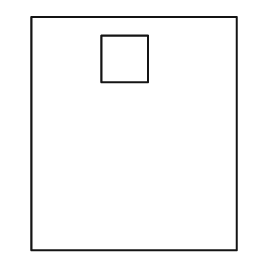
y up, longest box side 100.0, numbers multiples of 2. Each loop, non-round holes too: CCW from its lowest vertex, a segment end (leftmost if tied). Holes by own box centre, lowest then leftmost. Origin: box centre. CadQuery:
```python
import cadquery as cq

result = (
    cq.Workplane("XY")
    .moveTo(-44.0, -50.0)
    .lineTo(44.0, -50.0)
    .lineTo(44.0, 50.0)
    .lineTo(-44.0, 50.0)
    .close()
    .moveTo(-14.0, 22.0)
    .lineTo(6.0, 22.0)
    .lineTo(6.0, 42.0)
    .lineTo(-14.0, 42.0)
    .close()
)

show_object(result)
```